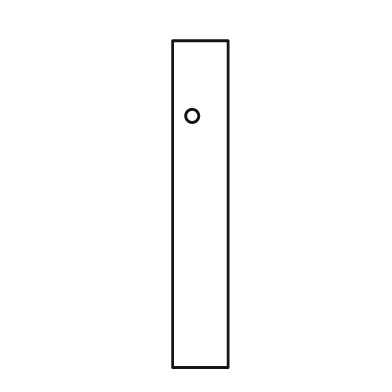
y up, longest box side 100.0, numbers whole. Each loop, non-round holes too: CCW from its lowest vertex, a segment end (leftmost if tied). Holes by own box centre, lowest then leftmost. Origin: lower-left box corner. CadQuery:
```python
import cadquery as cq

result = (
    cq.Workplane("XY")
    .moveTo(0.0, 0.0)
    .lineTo(17.0, 0.0)
    .lineTo(17.0, 100.0)
    .lineTo(0.0, 100.0)
    .close()
    .moveTo(6.0, 77.0)
    .circle(2.0)
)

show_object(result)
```